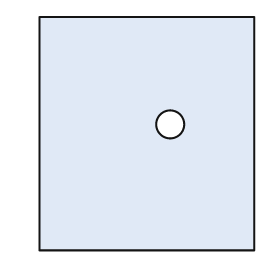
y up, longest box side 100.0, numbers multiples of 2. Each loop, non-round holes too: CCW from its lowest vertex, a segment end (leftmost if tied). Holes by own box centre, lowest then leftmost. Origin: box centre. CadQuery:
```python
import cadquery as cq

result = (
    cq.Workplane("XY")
    .moveTo(-46.0, -50.0)
    .lineTo(46.0, -50.0)
    .lineTo(46.0, 50.0)
    .lineTo(-46.0, 50.0)
    .close()
    .moveTo(10.0, 4.0)
    .circle(6.0)
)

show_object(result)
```